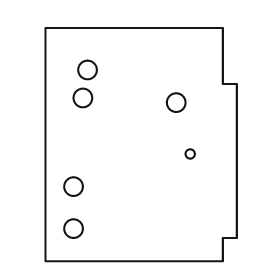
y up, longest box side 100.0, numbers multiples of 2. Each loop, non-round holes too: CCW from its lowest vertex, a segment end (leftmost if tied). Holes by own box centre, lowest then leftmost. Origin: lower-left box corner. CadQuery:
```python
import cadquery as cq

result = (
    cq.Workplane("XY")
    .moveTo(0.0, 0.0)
    .lineTo(76.0, 0.0)
    .lineTo(76.0, 10.0)
    .lineTo(82.0, 10.0)
    .lineTo(82.0, 76.0)
    .lineTo(76.0, 76.0)
    .lineTo(76.0, 100.0)
    .lineTo(0.0, 100.0)
    .close()
    .moveTo(12.0, 14.0)
    .circle(4.0)
    .moveTo(12.0, 32.0)
    .circle(4.0)
    .moveTo(62.0, 46.0)
    .circle(2.0)
    .moveTo(56.0, 68.0)
    .circle(4.0)
    .moveTo(16.0, 70.0)
    .circle(4.0)
    .moveTo(18.0, 82.0)
    .circle(4.0)
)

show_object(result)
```